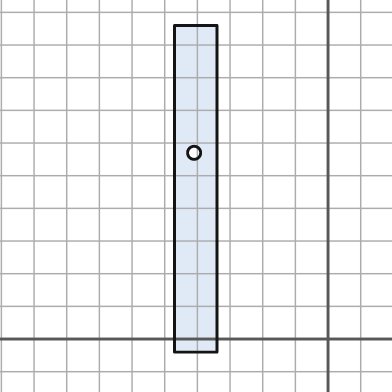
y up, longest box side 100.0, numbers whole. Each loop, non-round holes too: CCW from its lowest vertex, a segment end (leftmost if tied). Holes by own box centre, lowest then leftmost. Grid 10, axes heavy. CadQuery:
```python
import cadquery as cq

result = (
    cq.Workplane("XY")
    .moveTo(-47.0, -4.0)
    .lineTo(-34.0, -4.0)
    .lineTo(-34.0, 96.0)
    .lineTo(-47.0, 96.0)
    .close()
    .moveTo(-41.0, 57.0)
    .circle(2.0)
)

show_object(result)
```